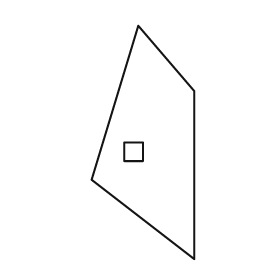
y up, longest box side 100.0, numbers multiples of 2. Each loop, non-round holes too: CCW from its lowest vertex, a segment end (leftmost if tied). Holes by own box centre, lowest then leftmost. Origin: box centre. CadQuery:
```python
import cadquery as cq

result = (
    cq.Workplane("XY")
    .moveTo(22.0, -50.0)
    .lineTo(22.0, 22.0)
    .lineTo(-2.0, 50.0)
    .lineTo(-22.0, -16.0)
    .close()
    .moveTo(-8.0, -8.0)
    .lineTo(0.0, -8.0)
    .lineTo(0.0, 0.0)
    .lineTo(-8.0, 0.0)
    .close()
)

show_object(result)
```